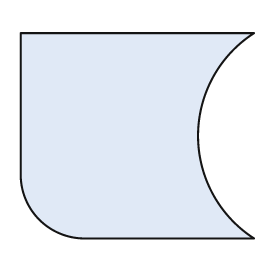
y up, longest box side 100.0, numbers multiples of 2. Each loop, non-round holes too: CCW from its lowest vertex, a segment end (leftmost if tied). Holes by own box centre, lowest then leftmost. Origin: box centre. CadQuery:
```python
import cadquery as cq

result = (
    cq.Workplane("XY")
    .moveTo(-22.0, -44.0)
    .lineTo(50.0, -44.0)
    .threePointArc((26.0, 0.0), (50.0, 44.0))
    .lineTo(-50.0, 44.0)
    .lineTo(-50.0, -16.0)
    .threePointArc((-42.0, -36.0), (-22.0, -44.0))
    .close()
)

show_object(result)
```